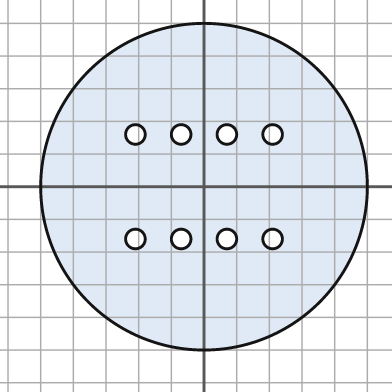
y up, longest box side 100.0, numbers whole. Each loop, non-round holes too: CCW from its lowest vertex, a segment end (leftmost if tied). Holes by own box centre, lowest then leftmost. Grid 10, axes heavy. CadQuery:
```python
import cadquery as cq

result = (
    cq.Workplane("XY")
    .moveTo(0.0, 0.0)
    .circle(50.0)
    .moveTo(-21.0, -16.0)
    .circle(3.0)
    .moveTo(-7.0, -16.0)
    .circle(3.0)
    .moveTo(7.0, -16.0)
    .circle(3.0)
    .moveTo(21.0, -16.0)
    .circle(3.0)
    .moveTo(-21.0, 16.0)
    .circle(3.0)
    .moveTo(-7.0, 16.0)
    .circle(3.0)
    .moveTo(7.0, 16.0)
    .circle(3.0)
    .moveTo(21.0, 16.0)
    .circle(3.0)
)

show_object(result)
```